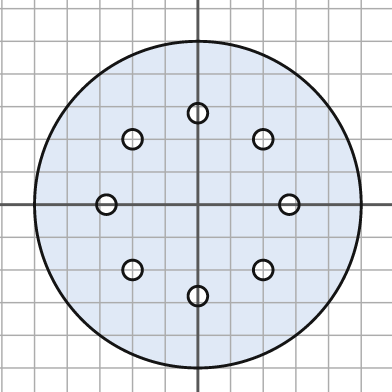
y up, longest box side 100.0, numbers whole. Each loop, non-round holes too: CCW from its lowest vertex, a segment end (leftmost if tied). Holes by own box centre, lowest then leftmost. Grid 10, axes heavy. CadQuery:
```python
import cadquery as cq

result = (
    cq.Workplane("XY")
    .moveTo(0.0, 0.0)
    .circle(50.0)
    .moveTo(0.0, -28.0)
    .circle(3.0)
    .moveTo(-20.0, -20.0)
    .circle(3.0)
    .moveTo(20.0, -20.0)
    .circle(3.0)
    .moveTo(-28.0, 0.0)
    .circle(3.0)
    .moveTo(28.0, 0.0)
    .circle(3.0)
    .moveTo(-20.0, 20.0)
    .circle(3.0)
    .moveTo(20.0, 20.0)
    .circle(3.0)
    .moveTo(0.0, 28.0)
    .circle(3.0)
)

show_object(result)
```